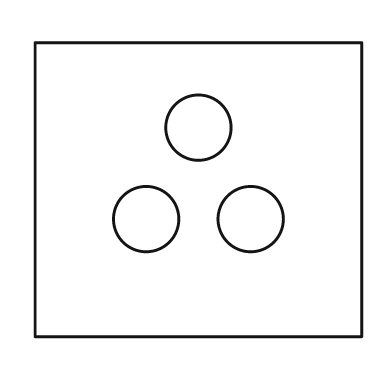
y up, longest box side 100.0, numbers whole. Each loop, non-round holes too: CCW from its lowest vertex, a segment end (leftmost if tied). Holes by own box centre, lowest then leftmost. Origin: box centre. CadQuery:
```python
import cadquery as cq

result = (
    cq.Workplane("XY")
    .moveTo(-50.0, -45.0)
    .lineTo(50.0, -45.0)
    .lineTo(50.0, 45.0)
    .lineTo(-50.0, 45.0)
    .close()
    .moveTo(-16.0, -9.0)
    .circle(10.0)
    .moveTo(16.0, -9.0)
    .circle(10.0)
    .moveTo(0.0, 19.0)
    .circle(10.0)
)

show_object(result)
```